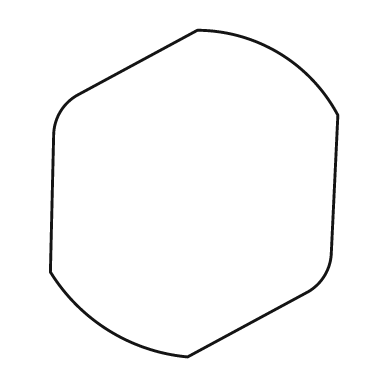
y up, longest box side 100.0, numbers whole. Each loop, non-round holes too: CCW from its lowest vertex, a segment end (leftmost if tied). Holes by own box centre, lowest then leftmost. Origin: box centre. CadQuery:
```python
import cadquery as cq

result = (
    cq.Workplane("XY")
    .moveTo(-2.0, -50.0)
    .lineTo(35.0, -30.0)
    .threePointArc((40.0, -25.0), (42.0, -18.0))
    .lineTo(44.0, 24.0)
    .threePointArc((26.0, 43.0), (1.0, 50.0))
    .lineTo(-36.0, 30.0)
    .threePointArc((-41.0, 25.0), (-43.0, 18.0))
    .lineTo(-44.0, -24.0)
    .threePointArc((-26.0, -42.0), (-2.0, -50.0))
    .close()
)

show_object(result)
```